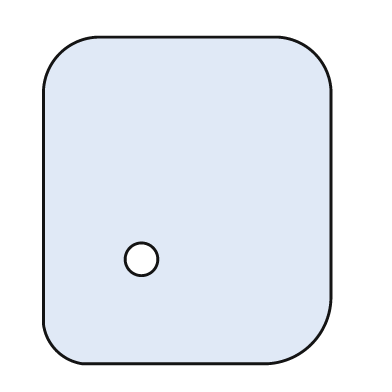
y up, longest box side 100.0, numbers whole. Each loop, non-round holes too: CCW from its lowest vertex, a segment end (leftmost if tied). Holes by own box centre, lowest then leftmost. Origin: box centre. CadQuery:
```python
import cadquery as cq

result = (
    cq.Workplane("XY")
    .moveTo(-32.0, -50.0)
    .lineTo(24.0, -50.0)
    .threePointArc((38.0, -44.0), (44.0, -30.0))
    .lineTo(44.0, 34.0)
    .threePointArc((39.0, 45.0), (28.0, 50.0))
    .lineTo(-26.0, 50.0)
    .threePointArc((-39.0, 45.0), (-44.0, 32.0))
    .lineTo(-44.0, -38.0)
    .threePointArc((-40.0, -46.0), (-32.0, -50.0))
    .close()
    .moveTo(-14.0, -18.0)
    .circle(5.0)
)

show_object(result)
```